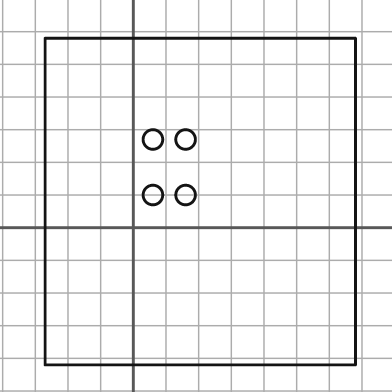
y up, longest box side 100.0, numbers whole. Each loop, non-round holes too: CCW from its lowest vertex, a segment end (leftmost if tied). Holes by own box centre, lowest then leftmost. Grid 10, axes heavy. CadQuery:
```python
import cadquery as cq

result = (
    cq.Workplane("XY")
    .moveTo(-27.0, -42.0)
    .lineTo(68.0, -42.0)
    .lineTo(68.0, 58.0)
    .lineTo(-27.0, 58.0)
    .close()
    .moveTo(6.0, 10.0)
    .circle(3.0)
    .moveTo(16.0, 10.0)
    .circle(3.0)
    .moveTo(6.0, 27.0)
    .circle(3.0)
    .moveTo(16.0, 27.0)
    .circle(3.0)
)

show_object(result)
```